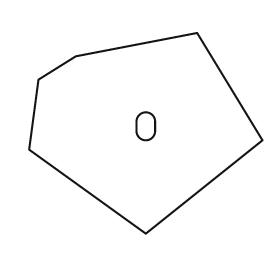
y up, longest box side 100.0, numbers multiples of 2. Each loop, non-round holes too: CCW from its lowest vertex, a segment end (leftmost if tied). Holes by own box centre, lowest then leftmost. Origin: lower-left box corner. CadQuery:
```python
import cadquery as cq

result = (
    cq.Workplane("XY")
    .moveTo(50.0, 0.0)
    .lineTo(100.0, 40.0)
    .lineTo(72.0, 86.0)
    .lineTo(20.0, 76.0)
    .lineTo(4.0, 66.0)
    .lineTo(0.0, 36.0)
    .close()
    .moveTo(46.0, 44.0)
    .threePointArc((50.0, 40.0), (54.0, 44.0))
    .lineTo(54.0, 48.0)
    .threePointArc((50.0, 52.0), (46.0, 48.0))
    .close()
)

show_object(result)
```